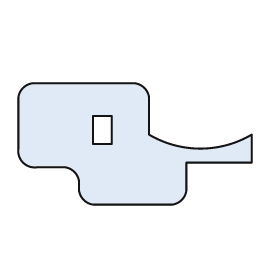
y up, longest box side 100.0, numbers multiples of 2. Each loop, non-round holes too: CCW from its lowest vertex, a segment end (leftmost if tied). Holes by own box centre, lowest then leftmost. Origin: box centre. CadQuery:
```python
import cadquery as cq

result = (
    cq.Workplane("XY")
    .moveTo(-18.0, -26.0)
    .lineTo(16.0, -26.0)
    .threePointArc((20.0, -24.0), (22.0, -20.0))
    .lineTo(22.0, -8.0)
    .lineTo(50.0, -8.0)
    .lineTo(50.0, 4.0)
    .threePointArc((28.0, -2.0), (6.0, 4.0))
    .lineTo(6.0, 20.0)
    .threePointArc((4.0, 24.0), (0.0, 26.0))
    .lineTo(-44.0, 26.0)
    .threePointArc((-48.0, 24.0), (-50.0, 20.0))
    .lineTo(-50.0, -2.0)
    .threePointArc((-48.0, -8.0), (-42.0, -10.0))
    .lineTo(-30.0, -10.0)
    .threePointArc((-26.0, -12.0), (-24.0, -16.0))
    .lineTo(-24.0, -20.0)
    .threePointArc((-22.0, -24.0), (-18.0, -26.0))
    .close()
    .moveTo(-18.0, 0.0)
    .lineTo(-10.0, 0.0)
    .lineTo(-10.0, 12.0)
    .lineTo(-18.0, 12.0)
    .close()
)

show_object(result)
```